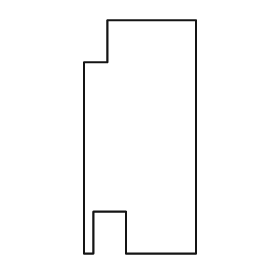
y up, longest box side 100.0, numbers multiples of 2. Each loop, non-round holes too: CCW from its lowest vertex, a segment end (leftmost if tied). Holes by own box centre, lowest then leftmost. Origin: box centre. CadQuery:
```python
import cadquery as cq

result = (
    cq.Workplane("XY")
    .moveTo(-24.0, -50.0)
    .lineTo(-20.0, -50.0)
    .lineTo(-20.0, -32.0)
    .lineTo(-6.0, -32.0)
    .lineTo(-6.0, -50.0)
    .lineTo(24.0, -50.0)
    .lineTo(24.0, 50.0)
    .lineTo(-14.0, 50.0)
    .lineTo(-14.0, 32.0)
    .lineTo(-24.0, 32.0)
    .close()
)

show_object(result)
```